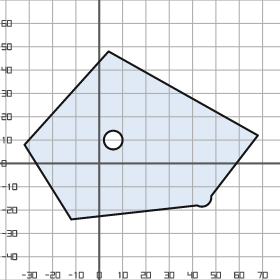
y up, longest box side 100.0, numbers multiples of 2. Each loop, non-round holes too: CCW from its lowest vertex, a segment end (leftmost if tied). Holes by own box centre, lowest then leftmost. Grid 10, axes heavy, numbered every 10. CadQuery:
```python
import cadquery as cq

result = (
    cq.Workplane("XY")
    .moveTo(-12.0, -24.0)
    .lineTo(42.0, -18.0)
    .threePointArc((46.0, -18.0), (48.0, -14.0))
    .lineTo(68.0, 12.0)
    .lineTo(4.0, 48.0)
    .lineTo(-32.0, 8.0)
    .close()
    .moveTo(6.0, 10.0)
    .circle(4.0)
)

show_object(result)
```